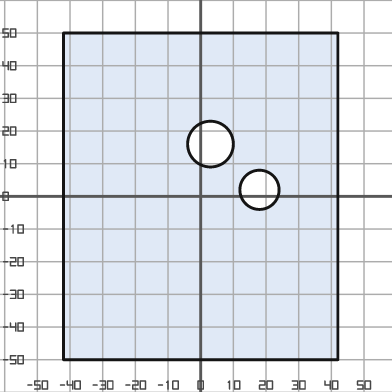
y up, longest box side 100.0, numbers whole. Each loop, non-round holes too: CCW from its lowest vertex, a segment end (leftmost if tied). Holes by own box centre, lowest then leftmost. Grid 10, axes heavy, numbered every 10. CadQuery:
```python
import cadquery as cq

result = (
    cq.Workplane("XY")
    .moveTo(-42.0, -50.0)
    .lineTo(42.0, -50.0)
    .lineTo(42.0, 50.0)
    .lineTo(-42.0, 50.0)
    .close()
    .moveTo(18.0, 2.0)
    .circle(6.0)
    .moveTo(3.0, 16.0)
    .circle(7.0)
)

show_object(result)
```